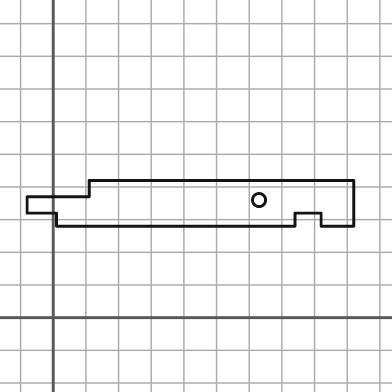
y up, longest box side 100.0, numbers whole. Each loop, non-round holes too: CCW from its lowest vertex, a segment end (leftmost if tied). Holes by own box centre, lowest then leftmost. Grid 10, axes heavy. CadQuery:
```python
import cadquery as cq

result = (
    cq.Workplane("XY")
    .moveTo(1.0, 28.0)
    .lineTo(74.0, 28.0)
    .lineTo(74.0, 32.0)
    .lineTo(82.0, 32.0)
    .lineTo(82.0, 28.0)
    .lineTo(92.0, 28.0)
    .lineTo(92.0, 42.0)
    .lineTo(11.0, 42.0)
    .lineTo(11.0, 37.0)
    .lineTo(-8.0, 37.0)
    .lineTo(-8.0, 32.0)
    .lineTo(1.0, 32.0)
    .close()
    .moveTo(63.0, 36.0)
    .circle(2.0)
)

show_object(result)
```